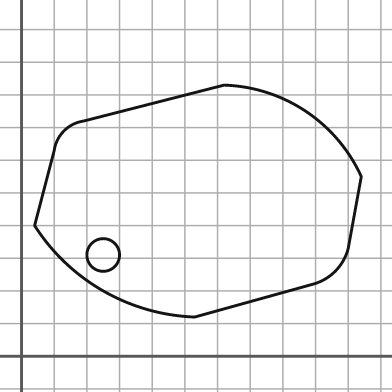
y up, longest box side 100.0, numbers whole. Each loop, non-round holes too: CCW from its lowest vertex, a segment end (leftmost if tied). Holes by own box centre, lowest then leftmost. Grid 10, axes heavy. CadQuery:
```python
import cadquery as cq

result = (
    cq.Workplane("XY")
    .moveTo(53.0, 12.0)
    .lineTo(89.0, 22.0)
    .threePointArc((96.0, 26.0), (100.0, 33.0))
    .lineTo(104.0, 55.0)
    .threePointArc((87.0, 75.0), (62.0, 83.0))
    .lineTo(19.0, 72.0)
    .threePointArc((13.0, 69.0), (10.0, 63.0))
    .lineTo(4.0, 40.0)
    .threePointArc((25.0, 20.0), (53.0, 12.0))
    .close()
    .moveTo(25.0, 31.0)
    .circle(5.0)
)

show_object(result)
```